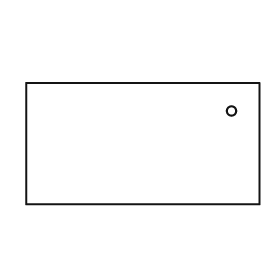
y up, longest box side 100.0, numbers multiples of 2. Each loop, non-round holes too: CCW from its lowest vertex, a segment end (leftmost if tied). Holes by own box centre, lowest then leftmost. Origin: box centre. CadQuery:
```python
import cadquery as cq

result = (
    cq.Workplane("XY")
    .moveTo(-50.0, -26.0)
    .lineTo(50.0, -26.0)
    .lineTo(50.0, 26.0)
    .lineTo(-50.0, 26.0)
    .close()
    .moveTo(38.0, 14.0)
    .circle(2.0)
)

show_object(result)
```